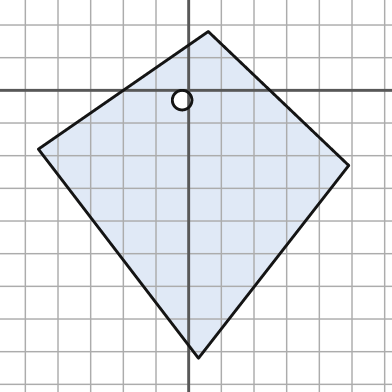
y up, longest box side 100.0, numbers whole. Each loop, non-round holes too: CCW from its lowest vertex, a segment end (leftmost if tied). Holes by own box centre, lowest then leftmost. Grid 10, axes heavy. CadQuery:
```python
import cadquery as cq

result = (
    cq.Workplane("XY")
    .moveTo(3.0, -82.0)
    .lineTo(49.0, -23.0)
    .lineTo(6.0, 18.0)
    .lineTo(-46.0, -18.0)
    .close()
    .moveTo(-2.0, -3.0)
    .circle(3.0)
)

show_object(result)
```